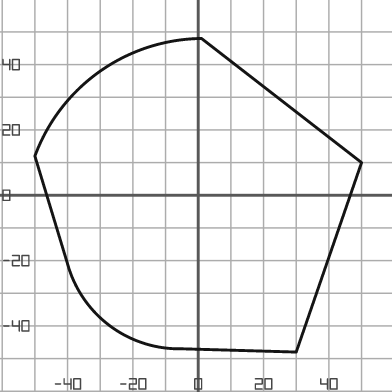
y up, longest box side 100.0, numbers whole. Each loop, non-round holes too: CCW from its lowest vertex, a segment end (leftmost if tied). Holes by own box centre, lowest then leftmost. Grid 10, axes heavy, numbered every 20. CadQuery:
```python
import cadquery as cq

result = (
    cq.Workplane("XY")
    .moveTo(30.0, -48.0)
    .lineTo(50.0, 10.0)
    .lineTo(1.0, 48.0)
    .threePointArc((-30.0, 38.0), (-50.0, 12.0))
    .lineTo(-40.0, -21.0)
    .threePointArc((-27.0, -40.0), (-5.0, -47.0))
    .close()
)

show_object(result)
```